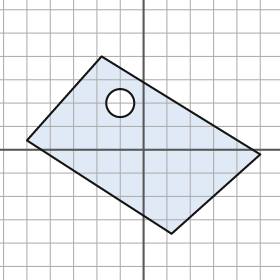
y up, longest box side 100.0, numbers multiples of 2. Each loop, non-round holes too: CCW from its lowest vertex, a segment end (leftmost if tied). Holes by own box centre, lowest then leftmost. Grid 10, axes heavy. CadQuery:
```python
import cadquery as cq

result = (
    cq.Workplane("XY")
    .moveTo(12.0, -36.0)
    .lineTo(50.0, -2.0)
    .lineTo(-18.0, 40.0)
    .lineTo(-50.0, 4.0)
    .close()
    .moveTo(-10.0, 20.0)
    .circle(6.0)
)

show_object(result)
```